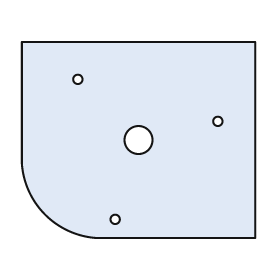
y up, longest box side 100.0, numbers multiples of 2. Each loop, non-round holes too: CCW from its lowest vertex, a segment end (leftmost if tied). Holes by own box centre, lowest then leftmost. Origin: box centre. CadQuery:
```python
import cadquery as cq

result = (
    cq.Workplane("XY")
    .moveTo(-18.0, -42.0)
    .lineTo(50.0, -42.0)
    .lineTo(50.0, 42.0)
    .lineTo(-50.0, 42.0)
    .lineTo(-50.0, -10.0)
    .threePointArc((-40.0, -32.0), (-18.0, -42.0))
    .close()
    .moveTo(-10.0, -34.0)
    .circle(2.0)
    .moveTo(0.0, 0.0)
    .circle(6.0)
    .moveTo(34.0, 8.0)
    .circle(2.0)
    .moveTo(-26.0, 26.0)
    .circle(2.0)
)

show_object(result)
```